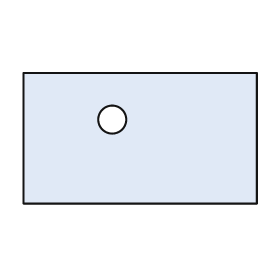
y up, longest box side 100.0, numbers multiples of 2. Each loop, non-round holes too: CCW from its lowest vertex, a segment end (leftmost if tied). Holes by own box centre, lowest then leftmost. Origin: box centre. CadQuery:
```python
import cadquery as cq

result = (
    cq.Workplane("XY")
    .moveTo(-50.0, -28.0)
    .lineTo(50.0, -28.0)
    .lineTo(50.0, 28.0)
    .lineTo(-50.0, 28.0)
    .close()
    .moveTo(-12.0, 8.0)
    .circle(6.0)
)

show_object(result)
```